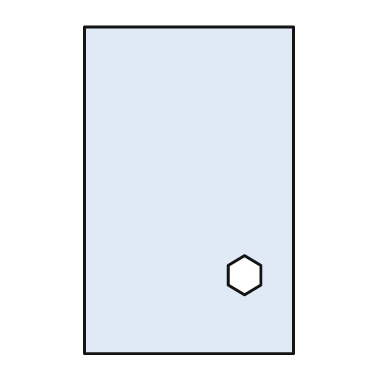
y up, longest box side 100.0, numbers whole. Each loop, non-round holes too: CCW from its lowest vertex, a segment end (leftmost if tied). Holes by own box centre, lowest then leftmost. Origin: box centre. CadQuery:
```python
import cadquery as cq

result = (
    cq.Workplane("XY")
    .moveTo(-32.0, -50.0)
    .lineTo(32.0, -50.0)
    .lineTo(32.0, 50.0)
    .lineTo(-32.0, 50.0)
    .close()
    .moveTo(17.0, -32.0)
    .lineTo(22.0, -29.0)
    .lineTo(22.0, -23.0)
    .lineTo(17.0, -20.0)
    .lineTo(12.0, -23.0)
    .lineTo(12.0, -29.0)
    .close()
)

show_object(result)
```